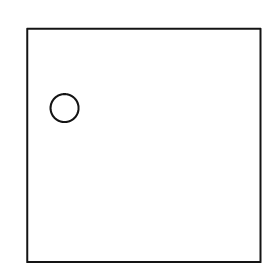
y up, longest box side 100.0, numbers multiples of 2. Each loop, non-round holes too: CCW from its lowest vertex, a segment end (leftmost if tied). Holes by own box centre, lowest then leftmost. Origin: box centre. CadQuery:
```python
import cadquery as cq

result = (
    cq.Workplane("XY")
    .moveTo(-50.0, -50.0)
    .lineTo(50.0, -50.0)
    .lineTo(50.0, 50.0)
    .lineTo(-50.0, 50.0)
    .close()
    .moveTo(-34.0, 16.0)
    .circle(6.0)
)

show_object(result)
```